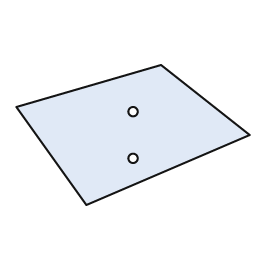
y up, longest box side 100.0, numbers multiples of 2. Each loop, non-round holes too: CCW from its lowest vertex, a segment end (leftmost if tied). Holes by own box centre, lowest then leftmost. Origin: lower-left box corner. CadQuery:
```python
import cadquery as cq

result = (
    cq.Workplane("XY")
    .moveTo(30.0, 0.0)
    .lineTo(100.0, 30.0)
    .lineTo(62.0, 60.0)
    .lineTo(0.0, 42.0)
    .close()
    .moveTo(50.0, 20.0)
    .circle(2.0)
    .moveTo(50.0, 40.0)
    .circle(2.0)
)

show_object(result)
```